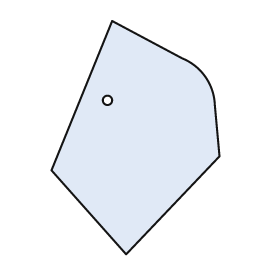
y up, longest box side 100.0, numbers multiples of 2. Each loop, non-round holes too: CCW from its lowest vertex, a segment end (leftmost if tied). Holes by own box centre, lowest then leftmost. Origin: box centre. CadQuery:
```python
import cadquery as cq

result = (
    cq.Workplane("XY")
    .moveTo(-4.0, -50.0)
    .lineTo(36.0, -8.0)
    .lineTo(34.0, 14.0)
    .threePointArc((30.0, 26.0), (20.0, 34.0))
    .lineTo(-10.0, 50.0)
    .lineTo(-36.0, -14.0)
    .close()
    .moveTo(-12.0, 16.0)
    .circle(2.0)
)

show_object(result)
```